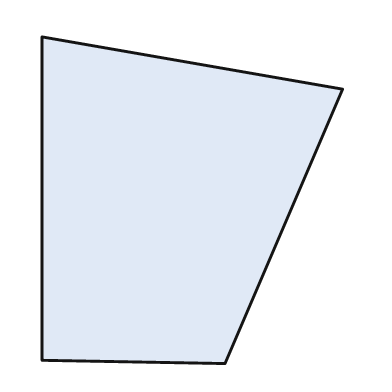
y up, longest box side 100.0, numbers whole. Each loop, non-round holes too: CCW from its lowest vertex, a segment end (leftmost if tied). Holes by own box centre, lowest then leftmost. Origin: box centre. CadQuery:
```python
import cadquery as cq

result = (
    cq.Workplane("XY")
    .moveTo(10.0, -50.0)
    .lineTo(46.0, 34.0)
    .lineTo(-46.0, 50.0)
    .lineTo(-46.0, -49.0)
    .close()
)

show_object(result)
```